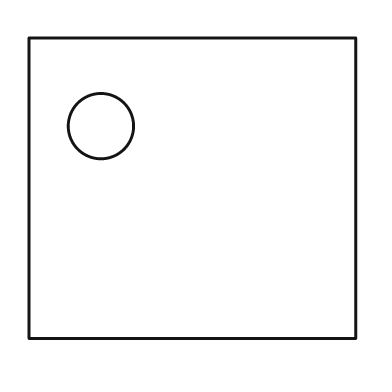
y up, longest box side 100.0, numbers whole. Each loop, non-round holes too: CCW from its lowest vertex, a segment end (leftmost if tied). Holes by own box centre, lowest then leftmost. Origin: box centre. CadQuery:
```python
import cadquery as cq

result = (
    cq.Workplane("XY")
    .moveTo(-50.0, -46.0)
    .lineTo(50.0, -46.0)
    .lineTo(50.0, 46.0)
    .lineTo(-50.0, 46.0)
    .close()
    .moveTo(-28.0, 19.0)
    .circle(10.0)
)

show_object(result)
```